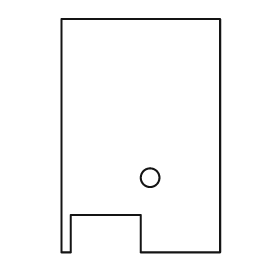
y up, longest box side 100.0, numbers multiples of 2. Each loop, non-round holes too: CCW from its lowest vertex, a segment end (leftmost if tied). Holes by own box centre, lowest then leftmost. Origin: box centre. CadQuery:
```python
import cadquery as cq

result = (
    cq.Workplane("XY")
    .moveTo(-34.0, -50.0)
    .lineTo(-30.0, -50.0)
    .lineTo(-30.0, -34.0)
    .lineTo(0.0, -34.0)
    .lineTo(0.0, -50.0)
    .lineTo(34.0, -50.0)
    .lineTo(34.0, 50.0)
    .lineTo(-34.0, 50.0)
    .close()
    .moveTo(4.0, -18.0)
    .circle(4.0)
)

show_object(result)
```